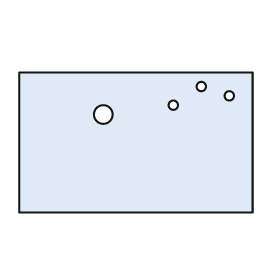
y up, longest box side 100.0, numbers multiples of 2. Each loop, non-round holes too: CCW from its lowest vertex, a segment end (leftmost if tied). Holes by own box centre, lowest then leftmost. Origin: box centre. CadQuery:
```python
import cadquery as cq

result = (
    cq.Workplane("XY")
    .moveTo(-50.0, -30.0)
    .lineTo(50.0, -30.0)
    .lineTo(50.0, 30.0)
    .lineTo(-50.0, 30.0)
    .close()
    .moveTo(-14.0, 12.0)
    .circle(4.0)
    .moveTo(16.0, 16.0)
    .circle(2.0)
    .moveTo(40.0, 20.0)
    .circle(2.0)
    .moveTo(28.0, 24.0)
    .circle(2.0)
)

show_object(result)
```